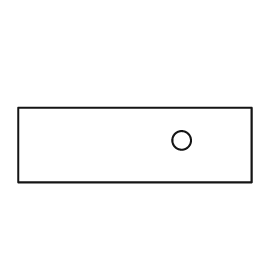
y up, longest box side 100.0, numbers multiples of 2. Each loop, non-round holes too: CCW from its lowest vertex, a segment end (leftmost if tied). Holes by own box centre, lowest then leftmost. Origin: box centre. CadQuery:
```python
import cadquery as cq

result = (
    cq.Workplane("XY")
    .moveTo(-50.0, -16.0)
    .lineTo(50.0, -16.0)
    .lineTo(50.0, 16.0)
    .lineTo(-50.0, 16.0)
    .close()
    .moveTo(20.0, 2.0)
    .circle(4.0)
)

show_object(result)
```